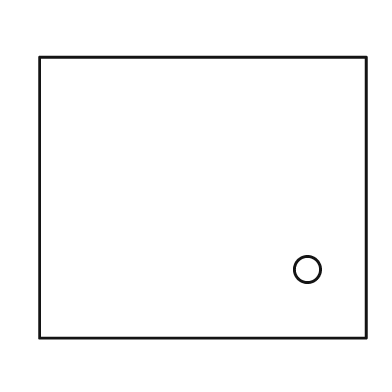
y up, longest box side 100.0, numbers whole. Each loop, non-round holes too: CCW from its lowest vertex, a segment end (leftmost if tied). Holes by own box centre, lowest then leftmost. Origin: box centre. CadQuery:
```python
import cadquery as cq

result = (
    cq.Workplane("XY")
    .moveTo(-50.0, -43.0)
    .lineTo(50.0, -43.0)
    .lineTo(50.0, 43.0)
    .lineTo(-50.0, 43.0)
    .close()
    .moveTo(32.0, -22.0)
    .circle(4.0)
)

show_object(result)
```